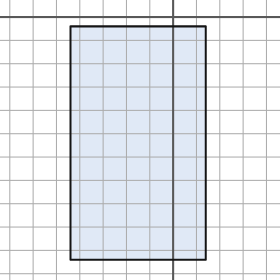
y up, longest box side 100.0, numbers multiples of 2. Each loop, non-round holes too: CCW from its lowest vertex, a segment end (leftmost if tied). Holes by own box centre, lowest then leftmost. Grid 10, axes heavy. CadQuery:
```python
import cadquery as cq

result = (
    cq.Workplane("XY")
    .moveTo(-44.0, -104.0)
    .lineTo(14.0, -104.0)
    .lineTo(14.0, -4.0)
    .lineTo(-44.0, -4.0)
    .close()
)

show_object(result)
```